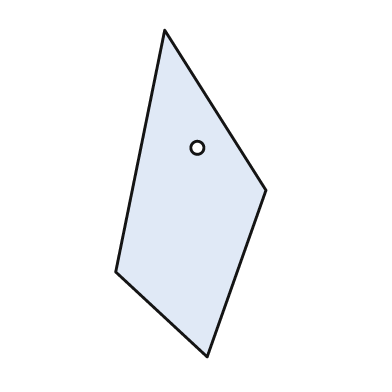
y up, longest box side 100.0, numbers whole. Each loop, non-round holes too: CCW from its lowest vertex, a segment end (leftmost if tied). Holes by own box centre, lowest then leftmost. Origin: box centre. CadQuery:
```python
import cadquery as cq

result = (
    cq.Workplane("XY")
    .moveTo(5.0, -50.0)
    .lineTo(23.0, 1.0)
    .lineTo(-8.0, 50.0)
    .lineTo(-23.0, -24.0)
    .close()
    .moveTo(2.0, 14.0)
    .circle(2.0)
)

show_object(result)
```